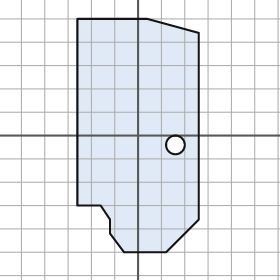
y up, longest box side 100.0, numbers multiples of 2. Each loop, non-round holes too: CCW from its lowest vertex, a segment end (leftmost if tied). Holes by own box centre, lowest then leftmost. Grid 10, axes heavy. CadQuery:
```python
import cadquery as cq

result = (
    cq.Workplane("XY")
    .moveTo(-6.0, -50.0)
    .lineTo(12.0, -50.0)
    .lineTo(26.0, -36.0)
    .lineTo(26.0, 44.0)
    .lineTo(4.0, 50.0)
    .lineTo(-26.0, 50.0)
    .lineTo(-26.0, -30.0)
    .lineTo(-16.0, -30.0)
    .lineTo(-12.0, -36.0)
    .lineTo(-12.0, -42.0)
    .close()
    .moveTo(16.0, -4.0)
    .circle(4.0)
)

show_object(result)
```